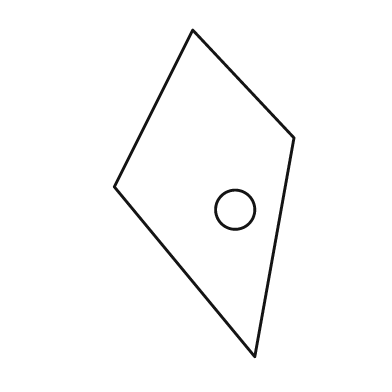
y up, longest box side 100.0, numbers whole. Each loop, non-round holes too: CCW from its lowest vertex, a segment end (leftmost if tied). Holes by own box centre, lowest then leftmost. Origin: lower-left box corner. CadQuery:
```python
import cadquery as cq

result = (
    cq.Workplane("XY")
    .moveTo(43.0, 0.0)
    .lineTo(55.0, 67.0)
    .lineTo(24.0, 100.0)
    .lineTo(0.0, 52.0)
    .close()
    .moveTo(37.0, 45.0)
    .circle(6.0)
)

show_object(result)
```